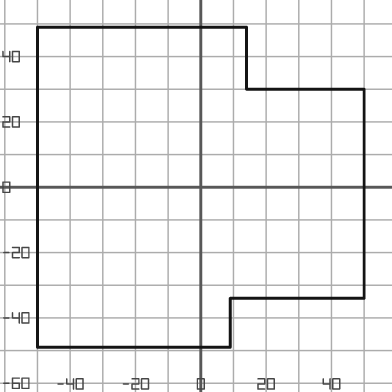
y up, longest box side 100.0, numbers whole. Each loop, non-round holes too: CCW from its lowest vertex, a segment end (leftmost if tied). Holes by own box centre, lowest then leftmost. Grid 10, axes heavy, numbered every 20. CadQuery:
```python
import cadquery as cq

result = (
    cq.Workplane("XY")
    .moveTo(-50.0, -49.0)
    .lineTo(9.0, -49.0)
    .lineTo(9.0, -34.0)
    .lineTo(50.0, -34.0)
    .lineTo(50.0, 30.0)
    .lineTo(14.0, 30.0)
    .lineTo(14.0, 49.0)
    .lineTo(-50.0, 49.0)
    .close()
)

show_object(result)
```